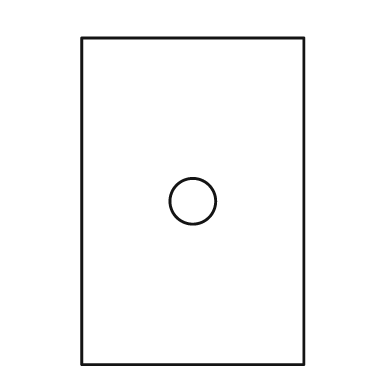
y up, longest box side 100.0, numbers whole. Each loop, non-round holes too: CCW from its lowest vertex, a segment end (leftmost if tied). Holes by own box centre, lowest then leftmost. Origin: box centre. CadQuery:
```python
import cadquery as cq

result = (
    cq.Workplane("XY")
    .moveTo(-34.0, -50.0)
    .lineTo(34.0, -50.0)
    .lineTo(34.0, 50.0)
    .lineTo(-34.0, 50.0)
    .close()
    .moveTo(0.0, 0.0)
    .circle(7.0)
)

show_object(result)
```